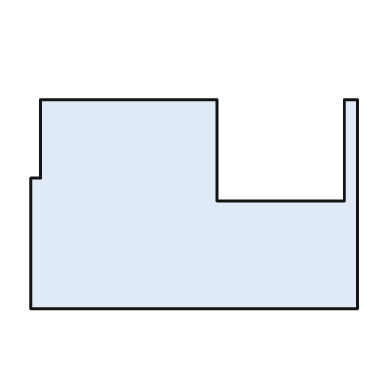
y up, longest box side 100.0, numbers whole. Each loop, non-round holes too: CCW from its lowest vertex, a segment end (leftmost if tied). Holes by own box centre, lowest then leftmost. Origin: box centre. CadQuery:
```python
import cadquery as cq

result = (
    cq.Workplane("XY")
    .moveTo(-50.0, -32.0)
    .lineTo(50.0, -32.0)
    .lineTo(50.0, 32.0)
    .lineTo(46.0, 32.0)
    .lineTo(46.0, 1.0)
    .lineTo(7.0, 1.0)
    .lineTo(7.0, 32.0)
    .lineTo(-47.0, 32.0)
    .lineTo(-47.0, 8.0)
    .lineTo(-50.0, 8.0)
    .close()
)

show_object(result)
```